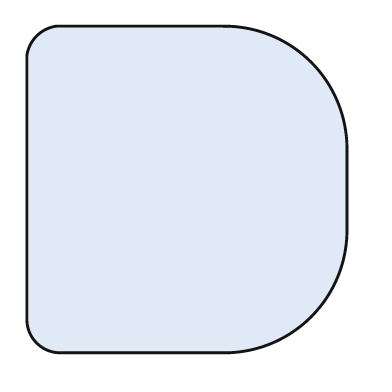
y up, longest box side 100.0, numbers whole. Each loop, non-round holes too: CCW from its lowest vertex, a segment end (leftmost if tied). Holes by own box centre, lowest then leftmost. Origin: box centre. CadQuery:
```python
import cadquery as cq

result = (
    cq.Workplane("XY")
    .moveTo(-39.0, -50.0)
    .lineTo(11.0, -50.0)
    .threePointArc((38.0, -39.0), (49.0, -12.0))
    .lineTo(49.0, 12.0)
    .threePointArc((38.0, 39.0), (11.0, 50.0))
    .lineTo(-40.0, 50.0)
    .threePointArc((-46.0, 47.0), (-49.0, 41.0))
    .lineTo(-49.0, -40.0)
    .threePointArc((-46.0, -47.0), (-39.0, -50.0))
    .close()
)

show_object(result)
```